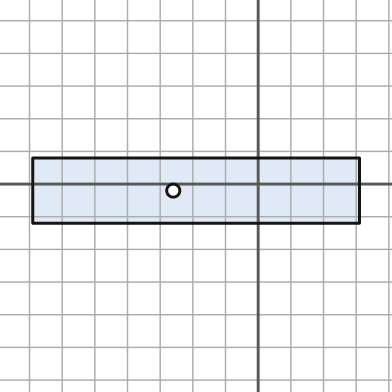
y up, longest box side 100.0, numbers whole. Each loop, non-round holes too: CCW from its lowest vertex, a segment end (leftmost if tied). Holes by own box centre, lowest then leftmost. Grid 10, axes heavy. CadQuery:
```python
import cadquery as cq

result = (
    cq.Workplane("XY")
    .moveTo(-69.0, -12.0)
    .lineTo(31.0, -12.0)
    .lineTo(31.0, 8.0)
    .lineTo(-69.0, 8.0)
    .close()
    .moveTo(-26.0, -2.0)
    .circle(2.0)
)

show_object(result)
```